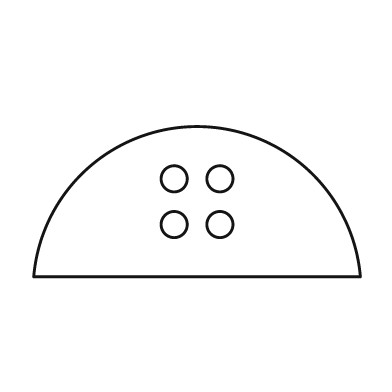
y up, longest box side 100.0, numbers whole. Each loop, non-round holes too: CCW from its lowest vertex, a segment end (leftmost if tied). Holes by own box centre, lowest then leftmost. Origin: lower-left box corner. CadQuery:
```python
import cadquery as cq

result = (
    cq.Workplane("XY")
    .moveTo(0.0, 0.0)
    .lineTo(100.0, 0.0)
    .threePointArc((50.0, 46.0), (0.0, 0.0))
    .close()
    .moveTo(43.0, 16.0)
    .circle(4.0)
    .moveTo(57.0, 16.0)
    .circle(4.0)
    .moveTo(43.0, 30.0)
    .circle(4.0)
    .moveTo(57.0, 30.0)
    .circle(4.0)
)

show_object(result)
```